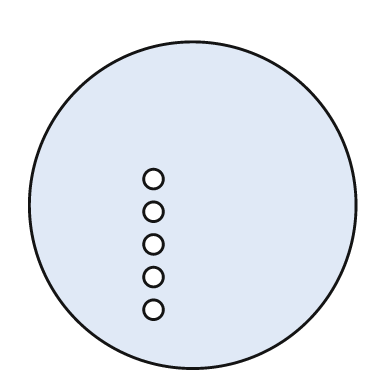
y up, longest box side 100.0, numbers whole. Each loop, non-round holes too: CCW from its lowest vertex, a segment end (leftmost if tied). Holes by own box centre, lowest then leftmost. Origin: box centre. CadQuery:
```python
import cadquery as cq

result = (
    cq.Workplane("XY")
    .moveTo(0.0, 0.0)
    .circle(50.0)
    .moveTo(-12.0, -32.0)
    .circle(3.0)
    .moveTo(-12.0, -22.0)
    .circle(3.0)
    .moveTo(-12.0, -12.0)
    .circle(3.0)
    .moveTo(-12.0, -2.0)
    .circle(3.0)
    .moveTo(-12.0, 8.0)
    .circle(3.0)
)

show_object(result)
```